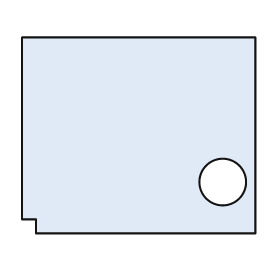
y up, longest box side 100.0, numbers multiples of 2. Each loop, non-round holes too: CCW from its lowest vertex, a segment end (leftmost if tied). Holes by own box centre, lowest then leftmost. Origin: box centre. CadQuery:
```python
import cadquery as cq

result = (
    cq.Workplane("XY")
    .moveTo(-44.0, -42.0)
    .lineTo(50.0, -42.0)
    .lineTo(50.0, 42.0)
    .lineTo(-50.0, 42.0)
    .lineTo(-50.0, -36.0)
    .lineTo(-44.0, -36.0)
    .close()
    .moveTo(36.0, -20.0)
    .circle(10.0)
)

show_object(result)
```